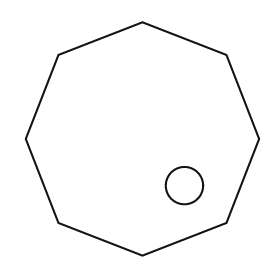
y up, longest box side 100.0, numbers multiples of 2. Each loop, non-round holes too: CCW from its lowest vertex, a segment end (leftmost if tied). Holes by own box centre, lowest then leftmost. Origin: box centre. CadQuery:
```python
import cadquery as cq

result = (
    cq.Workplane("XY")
    .moveTo(0.0, -50.0)
    .lineTo(36.0, -36.0)
    .lineTo(50.0, 0.0)
    .lineTo(36.0, 36.0)
    .lineTo(0.0, 50.0)
    .lineTo(-36.0, 36.0)
    .lineTo(-50.0, 0.0)
    .lineTo(-36.0, -36.0)
    .close()
    .moveTo(18.0, -20.0)
    .circle(8.0)
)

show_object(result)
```